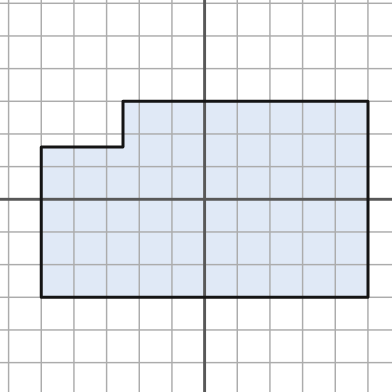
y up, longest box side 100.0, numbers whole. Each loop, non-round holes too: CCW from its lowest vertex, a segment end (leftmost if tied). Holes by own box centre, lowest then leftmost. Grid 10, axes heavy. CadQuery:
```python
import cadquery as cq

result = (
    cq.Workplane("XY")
    .moveTo(-50.0, -30.0)
    .lineTo(50.0, -30.0)
    .lineTo(50.0, 30.0)
    .lineTo(-25.0, 30.0)
    .lineTo(-25.0, 16.0)
    .lineTo(-50.0, 16.0)
    .close()
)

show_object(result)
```